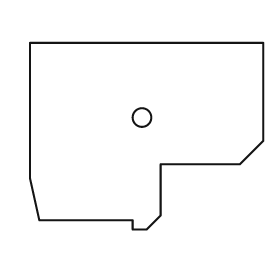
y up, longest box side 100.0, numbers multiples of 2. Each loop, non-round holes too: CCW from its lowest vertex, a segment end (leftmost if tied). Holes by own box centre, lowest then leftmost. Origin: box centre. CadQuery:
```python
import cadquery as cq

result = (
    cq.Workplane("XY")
    .moveTo(-6.0, -40.0)
    .lineTo(0.0, -40.0)
    .lineTo(6.0, -34.0)
    .lineTo(6.0, -12.0)
    .lineTo(40.0, -12.0)
    .lineTo(50.0, -2.0)
    .lineTo(50.0, 40.0)
    .lineTo(-50.0, 40.0)
    .lineTo(-50.0, -18.0)
    .lineTo(-46.0, -36.0)
    .lineTo(-6.0, -36.0)
    .close()
    .moveTo(-2.0, 8.0)
    .circle(4.0)
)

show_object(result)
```